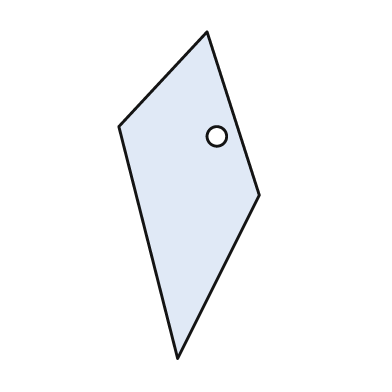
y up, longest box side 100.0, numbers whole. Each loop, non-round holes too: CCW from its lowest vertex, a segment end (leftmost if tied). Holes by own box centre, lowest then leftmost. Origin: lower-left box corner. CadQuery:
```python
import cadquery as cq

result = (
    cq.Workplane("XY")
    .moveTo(18.0, 0.0)
    .lineTo(43.0, 50.0)
    .lineTo(27.0, 100.0)
    .lineTo(0.0, 71.0)
    .close()
    .moveTo(30.0, 68.0)
    .circle(3.0)
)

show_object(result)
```